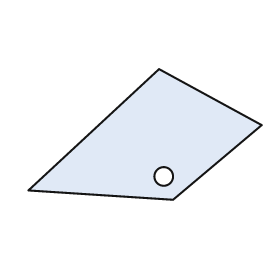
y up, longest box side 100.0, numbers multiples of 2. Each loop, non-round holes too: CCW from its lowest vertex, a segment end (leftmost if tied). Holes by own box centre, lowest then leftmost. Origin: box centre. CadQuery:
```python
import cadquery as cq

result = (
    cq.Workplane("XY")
    .moveTo(12.0, -28.0)
    .lineTo(50.0, 4.0)
    .lineTo(6.0, 28.0)
    .lineTo(-50.0, -24.0)
    .close()
    .moveTo(8.0, -18.0)
    .circle(4.0)
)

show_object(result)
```